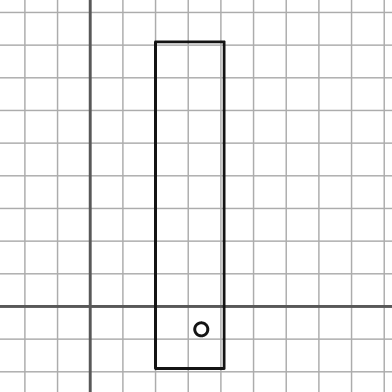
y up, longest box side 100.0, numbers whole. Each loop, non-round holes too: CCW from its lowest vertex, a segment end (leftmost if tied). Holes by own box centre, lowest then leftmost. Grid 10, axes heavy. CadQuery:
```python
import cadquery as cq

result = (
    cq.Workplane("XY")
    .moveTo(20.0, -19.0)
    .lineTo(41.0, -19.0)
    .lineTo(41.0, 81.0)
    .lineTo(20.0, 81.0)
    .close()
    .moveTo(34.0, -7.0)
    .circle(2.0)
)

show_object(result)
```